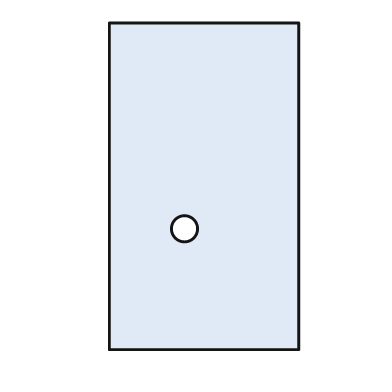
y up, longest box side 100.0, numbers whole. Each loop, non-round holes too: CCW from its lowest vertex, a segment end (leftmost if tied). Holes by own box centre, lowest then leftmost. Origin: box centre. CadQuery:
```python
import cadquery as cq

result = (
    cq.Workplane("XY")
    .moveTo(-29.0, -50.0)
    .lineTo(29.0, -50.0)
    .lineTo(29.0, 50.0)
    .lineTo(-29.0, 50.0)
    .close()
    .moveTo(-6.0, -13.0)
    .circle(4.0)
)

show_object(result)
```